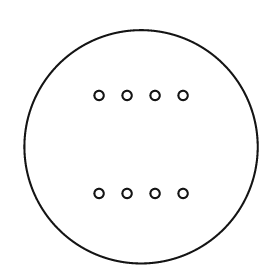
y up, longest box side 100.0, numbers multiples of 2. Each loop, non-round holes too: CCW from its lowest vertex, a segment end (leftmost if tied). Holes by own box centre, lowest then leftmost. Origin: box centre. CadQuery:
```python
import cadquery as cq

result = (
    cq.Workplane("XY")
    .moveTo(0.0, 0.0)
    .circle(50.0)
    .moveTo(-18.0, -20.0)
    .circle(2.0)
    .moveTo(-6.0, -20.0)
    .circle(2.0)
    .moveTo(6.0, -20.0)
    .circle(2.0)
    .moveTo(18.0, -20.0)
    .circle(2.0)
    .moveTo(-18.0, 22.0)
    .circle(2.0)
    .moveTo(-6.0, 22.0)
    .circle(2.0)
    .moveTo(6.0, 22.0)
    .circle(2.0)
    .moveTo(18.0, 22.0)
    .circle(2.0)
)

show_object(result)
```